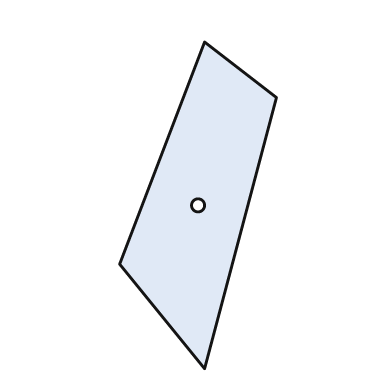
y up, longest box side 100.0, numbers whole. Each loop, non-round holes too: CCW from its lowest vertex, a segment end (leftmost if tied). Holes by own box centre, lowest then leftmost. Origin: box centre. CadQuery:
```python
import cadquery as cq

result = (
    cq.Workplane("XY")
    .moveTo(2.0, -50.0)
    .lineTo(24.0, 33.0)
    .lineTo(2.0, 50.0)
    .lineTo(-24.0, -18.0)
    .close()
    .moveTo(0.0, 0.0)
    .circle(2.0)
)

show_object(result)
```